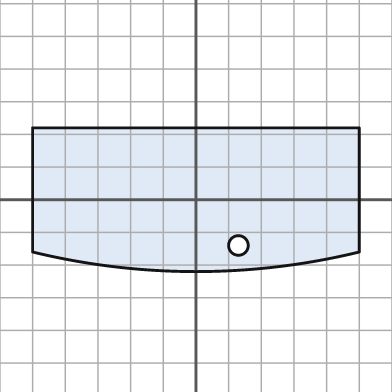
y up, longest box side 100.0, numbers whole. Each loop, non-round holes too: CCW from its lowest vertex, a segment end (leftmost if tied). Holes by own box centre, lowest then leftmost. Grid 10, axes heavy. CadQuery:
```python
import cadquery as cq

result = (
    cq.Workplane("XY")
    .moveTo(-50.0, -16.0)
    .threePointArc((0.0, -22.0), (50.0, -16.0))
    .lineTo(50.0, 22.0)
    .lineTo(-50.0, 22.0)
    .close()
    .moveTo(13.0, -14.0)
    .circle(3.0)
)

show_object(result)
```